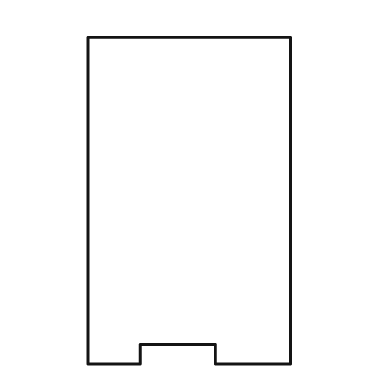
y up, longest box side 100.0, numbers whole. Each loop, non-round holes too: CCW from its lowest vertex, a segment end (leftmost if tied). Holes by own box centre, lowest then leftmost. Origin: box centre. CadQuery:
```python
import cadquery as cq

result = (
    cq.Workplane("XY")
    .moveTo(-31.0, -50.0)
    .lineTo(-15.0, -50.0)
    .lineTo(-15.0, -44.0)
    .lineTo(8.0, -44.0)
    .lineTo(8.0, -50.0)
    .lineTo(31.0, -50.0)
    .lineTo(31.0, 50.0)
    .lineTo(-31.0, 50.0)
    .close()
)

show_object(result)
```